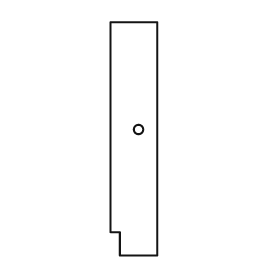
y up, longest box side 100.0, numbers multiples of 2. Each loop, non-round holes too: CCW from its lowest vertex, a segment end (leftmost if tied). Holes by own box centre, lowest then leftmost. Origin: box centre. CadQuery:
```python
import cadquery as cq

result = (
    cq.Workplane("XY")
    .moveTo(-6.0, -50.0)
    .lineTo(10.0, -50.0)
    .lineTo(10.0, 50.0)
    .lineTo(-10.0, 50.0)
    .lineTo(-10.0, -40.0)
    .lineTo(-6.0, -40.0)
    .close()
    .moveTo(2.0, 4.0)
    .circle(2.0)
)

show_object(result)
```